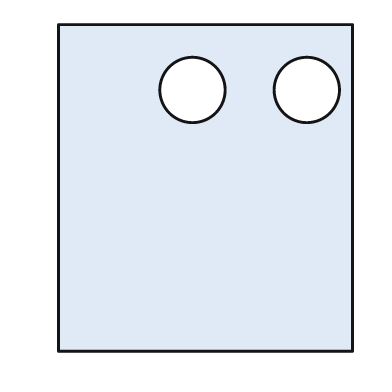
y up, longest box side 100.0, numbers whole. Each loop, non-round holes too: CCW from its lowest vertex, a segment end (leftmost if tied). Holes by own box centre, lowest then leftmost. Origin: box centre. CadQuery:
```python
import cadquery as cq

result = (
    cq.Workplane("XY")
    .moveTo(-45.0, -50.0)
    .lineTo(45.0, -50.0)
    .lineTo(45.0, 50.0)
    .lineTo(-45.0, 50.0)
    .close()
    .moveTo(-4.0, 30.0)
    .circle(10.0)
    .moveTo(31.0, 30.0)
    .circle(10.0)
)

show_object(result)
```